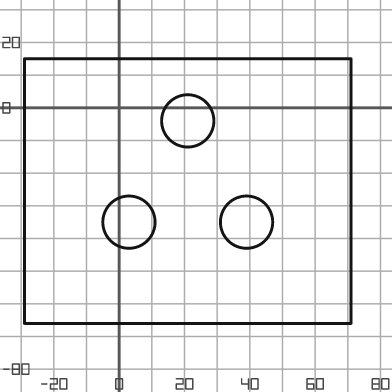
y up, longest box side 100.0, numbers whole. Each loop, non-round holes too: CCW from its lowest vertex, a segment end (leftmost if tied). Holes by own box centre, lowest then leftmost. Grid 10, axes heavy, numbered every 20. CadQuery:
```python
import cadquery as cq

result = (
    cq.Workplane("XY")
    .moveTo(-29.0, -66.0)
    .lineTo(71.0, -66.0)
    .lineTo(71.0, 15.0)
    .lineTo(-29.0, 15.0)
    .close()
    .moveTo(3.0, -35.0)
    .circle(8.0)
    .moveTo(39.0, -35.0)
    .circle(8.0)
    .moveTo(21.0, -4.0)
    .circle(8.0)
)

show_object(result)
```